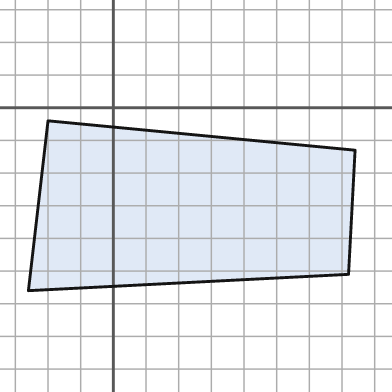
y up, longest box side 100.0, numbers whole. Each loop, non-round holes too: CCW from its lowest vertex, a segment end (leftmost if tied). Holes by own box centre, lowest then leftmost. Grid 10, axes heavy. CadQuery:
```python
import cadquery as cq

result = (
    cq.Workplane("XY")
    .moveTo(-26.0, -56.0)
    .lineTo(72.0, -51.0)
    .lineTo(74.0, -13.0)
    .lineTo(-20.0, -4.0)
    .close()
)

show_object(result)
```